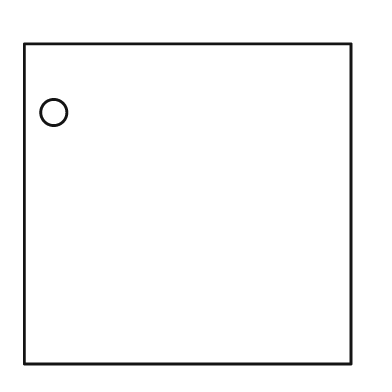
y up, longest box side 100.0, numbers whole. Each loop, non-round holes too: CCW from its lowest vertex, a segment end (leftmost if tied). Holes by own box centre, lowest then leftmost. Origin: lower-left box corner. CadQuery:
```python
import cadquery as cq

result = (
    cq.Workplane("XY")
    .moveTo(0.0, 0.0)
    .lineTo(100.0, 0.0)
    .lineTo(100.0, 98.0)
    .lineTo(0.0, 98.0)
    .close()
    .moveTo(9.0, 77.0)
    .circle(4.0)
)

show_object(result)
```